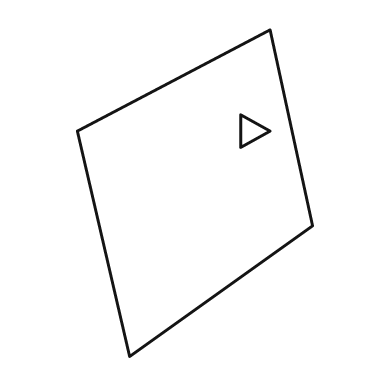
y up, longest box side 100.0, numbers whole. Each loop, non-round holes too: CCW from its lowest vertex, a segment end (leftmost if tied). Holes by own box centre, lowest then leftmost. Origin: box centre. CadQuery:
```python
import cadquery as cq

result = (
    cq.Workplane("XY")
    .moveTo(-20.0, -50.0)
    .lineTo(36.0, -10.0)
    .lineTo(23.0, 50.0)
    .lineTo(-36.0, 19.0)
    .close()
    .moveTo(14.0, 14.0)
    .lineTo(23.0, 19.0)
    .lineTo(14.0, 24.0)
    .close()
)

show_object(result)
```